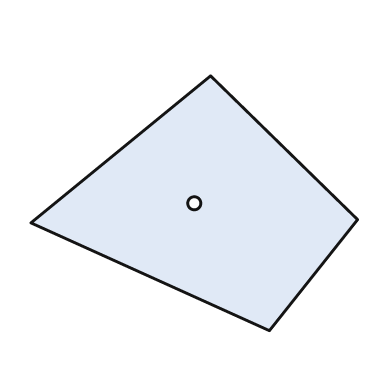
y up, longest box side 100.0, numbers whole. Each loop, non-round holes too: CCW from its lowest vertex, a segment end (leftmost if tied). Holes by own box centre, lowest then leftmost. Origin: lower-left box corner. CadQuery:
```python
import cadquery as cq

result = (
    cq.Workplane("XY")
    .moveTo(73.0, 0.0)
    .lineTo(100.0, 34.0)
    .lineTo(55.0, 78.0)
    .lineTo(0.0, 33.0)
    .close()
    .moveTo(50.0, 39.0)
    .circle(2.0)
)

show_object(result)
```